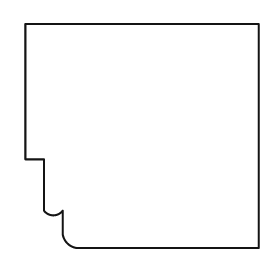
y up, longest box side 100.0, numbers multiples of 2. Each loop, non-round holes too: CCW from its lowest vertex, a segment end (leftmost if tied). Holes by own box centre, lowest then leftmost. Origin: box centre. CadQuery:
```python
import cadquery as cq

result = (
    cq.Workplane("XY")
    .moveTo(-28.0, -48.0)
    .lineTo(50.0, -48.0)
    .lineTo(50.0, 48.0)
    .lineTo(-50.0, 48.0)
    .lineTo(-50.0, -10.0)
    .lineTo(-42.0, -10.0)
    .lineTo(-42.0, -32.0)
    .threePointArc((-38.0, -34.0), (-34.0, -32.0))
    .lineTo(-34.0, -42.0)
    .threePointArc((-32.0, -46.0), (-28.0, -48.0))
    .close()
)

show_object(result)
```